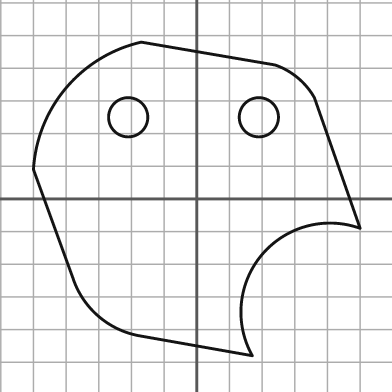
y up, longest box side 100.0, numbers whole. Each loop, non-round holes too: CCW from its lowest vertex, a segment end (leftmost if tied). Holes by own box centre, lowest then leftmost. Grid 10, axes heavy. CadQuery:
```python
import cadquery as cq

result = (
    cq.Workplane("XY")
    .moveTo(17.0, -48.0)
    .threePointArc((20.0, -17.0), (50.0, -9.0))
    .lineTo(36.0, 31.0)
    .threePointArc((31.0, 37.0), (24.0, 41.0))
    .lineTo(-17.0, 48.0)
    .threePointArc((-40.0, 34.0), (-50.0, 9.0))
    .lineTo(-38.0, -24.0)
    .threePointArc((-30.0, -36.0), (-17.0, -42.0))
    .close()
    .moveTo(-21.0, 25.0)
    .circle(6.0)
    .moveTo(19.0, 25.0)
    .circle(6.0)
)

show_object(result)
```